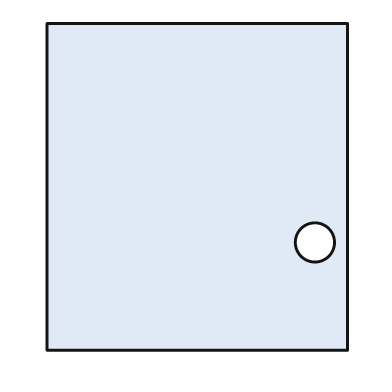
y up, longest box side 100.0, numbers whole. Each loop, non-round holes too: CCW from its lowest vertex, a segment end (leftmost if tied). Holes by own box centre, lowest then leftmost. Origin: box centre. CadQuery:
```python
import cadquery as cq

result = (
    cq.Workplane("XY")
    .moveTo(-46.0, -50.0)
    .lineTo(46.0, -50.0)
    .lineTo(46.0, 50.0)
    .lineTo(-46.0, 50.0)
    .close()
    .moveTo(36.0, -17.0)
    .circle(6.0)
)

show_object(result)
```